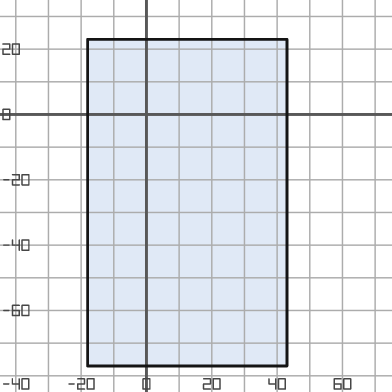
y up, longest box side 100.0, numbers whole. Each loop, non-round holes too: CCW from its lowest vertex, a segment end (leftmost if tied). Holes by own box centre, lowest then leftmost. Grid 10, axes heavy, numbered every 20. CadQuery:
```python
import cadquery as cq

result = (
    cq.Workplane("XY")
    .moveTo(-18.0, -77.0)
    .lineTo(43.0, -77.0)
    .lineTo(43.0, 23.0)
    .lineTo(-18.0, 23.0)
    .close()
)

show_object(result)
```